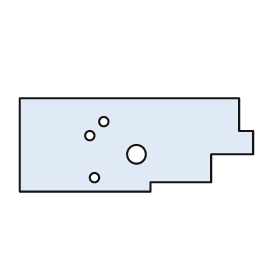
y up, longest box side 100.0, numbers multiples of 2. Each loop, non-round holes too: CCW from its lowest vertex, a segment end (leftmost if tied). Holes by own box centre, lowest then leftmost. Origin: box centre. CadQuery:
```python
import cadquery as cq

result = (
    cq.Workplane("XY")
    .moveTo(-50.0, -20.0)
    .lineTo(6.0, -20.0)
    .lineTo(6.0, -16.0)
    .lineTo(32.0, -16.0)
    .lineTo(32.0, -4.0)
    .lineTo(50.0, -4.0)
    .lineTo(50.0, 6.0)
    .lineTo(44.0, 6.0)
    .lineTo(44.0, 20.0)
    .lineTo(-50.0, 20.0)
    .close()
    .moveTo(-18.0, -14.0)
    .circle(2.0)
    .moveTo(0.0, -4.0)
    .circle(4.0)
    .moveTo(-20.0, 4.0)
    .circle(2.0)
    .moveTo(-14.0, 10.0)
    .circle(2.0)
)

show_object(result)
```